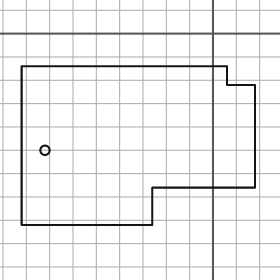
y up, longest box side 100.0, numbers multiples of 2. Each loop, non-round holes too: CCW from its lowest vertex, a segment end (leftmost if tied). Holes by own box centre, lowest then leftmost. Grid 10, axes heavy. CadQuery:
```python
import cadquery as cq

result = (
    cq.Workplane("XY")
    .moveTo(-82.0, -82.0)
    .lineTo(-26.0, -82.0)
    .lineTo(-26.0, -66.0)
    .lineTo(18.0, -66.0)
    .lineTo(18.0, -22.0)
    .lineTo(6.0, -22.0)
    .lineTo(6.0, -14.0)
    .lineTo(-82.0, -14.0)
    .close()
    .moveTo(-72.0, -50.0)
    .circle(2.0)
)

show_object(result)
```